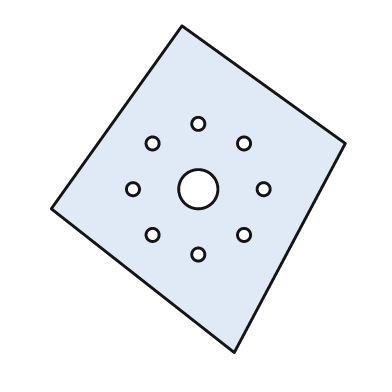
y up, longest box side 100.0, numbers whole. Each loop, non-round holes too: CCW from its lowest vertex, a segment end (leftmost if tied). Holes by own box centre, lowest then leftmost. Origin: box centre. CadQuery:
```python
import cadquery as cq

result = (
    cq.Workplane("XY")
    .moveTo(11.0, -50.0)
    .lineTo(45.0, 14.0)
    .lineTo(-5.0, 50.0)
    .lineTo(-45.0, -6.0)
    .close()
    .moveTo(0.0, -20.0)
    .circle(2.0)
    .moveTo(-14.0, -14.0)
    .circle(2.0)
    .moveTo(14.0, -14.0)
    .circle(2.0)
    .moveTo(-20.0, 0.0)
    .circle(2.0)
    .moveTo(0.0, 0.0)
    .circle(6.0)
    .moveTo(20.0, 0.0)
    .circle(2.0)
    .moveTo(-14.0, 14.0)
    .circle(2.0)
    .moveTo(14.0, 14.0)
    .circle(2.0)
    .moveTo(0.0, 20.0)
    .circle(2.0)
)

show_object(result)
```